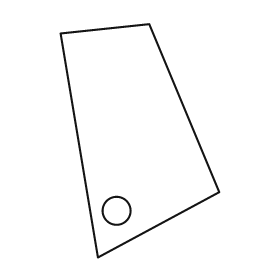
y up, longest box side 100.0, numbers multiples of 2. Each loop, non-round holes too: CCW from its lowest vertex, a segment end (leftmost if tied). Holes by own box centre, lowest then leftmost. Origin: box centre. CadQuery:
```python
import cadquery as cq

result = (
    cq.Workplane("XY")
    .moveTo(-18.0, -50.0)
    .lineTo(34.0, -22.0)
    .lineTo(4.0, 50.0)
    .lineTo(-34.0, 46.0)
    .close()
    .moveTo(-10.0, -30.0)
    .circle(6.0)
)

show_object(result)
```